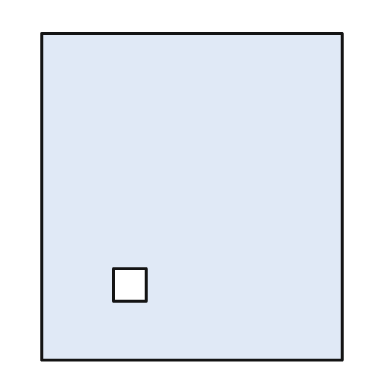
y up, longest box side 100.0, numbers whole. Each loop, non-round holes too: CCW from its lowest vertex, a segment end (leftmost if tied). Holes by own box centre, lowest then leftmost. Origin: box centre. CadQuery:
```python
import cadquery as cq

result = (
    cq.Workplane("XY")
    .moveTo(-46.0, -50.0)
    .lineTo(46.0, -50.0)
    .lineTo(46.0, 50.0)
    .lineTo(-46.0, 50.0)
    .close()
    .moveTo(-24.0, -32.0)
    .lineTo(-14.0, -32.0)
    .lineTo(-14.0, -22.0)
    .lineTo(-24.0, -22.0)
    .close()
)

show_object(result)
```